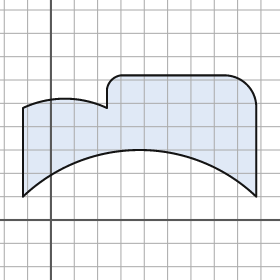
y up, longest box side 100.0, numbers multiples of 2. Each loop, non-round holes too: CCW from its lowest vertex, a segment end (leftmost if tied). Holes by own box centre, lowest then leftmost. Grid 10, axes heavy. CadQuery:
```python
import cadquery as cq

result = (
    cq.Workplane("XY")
    .moveTo(-12.0, 10.0)
    .threePointArc((38.0, 30.0), (88.0, 10.0))
    .lineTo(88.0, 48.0)
    .threePointArc((84.0, 58.0), (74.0, 62.0))
    .lineTo(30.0, 62.0)
    .threePointArc((26.0, 60.0), (24.0, 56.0))
    .lineTo(24.0, 48.0)
    .threePointArc((6.0, 52.0), (-12.0, 48.0))
    .close()
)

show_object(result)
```